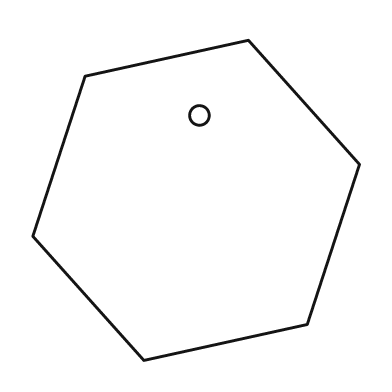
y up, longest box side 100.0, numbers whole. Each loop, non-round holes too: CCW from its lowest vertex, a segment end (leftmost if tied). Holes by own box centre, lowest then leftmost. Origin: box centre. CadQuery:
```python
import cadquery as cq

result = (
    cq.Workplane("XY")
    .moveTo(-16.0, -49.0)
    .lineTo(34.0, -38.0)
    .lineTo(50.0, 11.0)
    .lineTo(16.0, 49.0)
    .lineTo(-34.0, 38.0)
    .lineTo(-50.0, -11.0)
    .close()
    .moveTo(1.0, 26.0)
    .circle(3.0)
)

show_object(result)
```